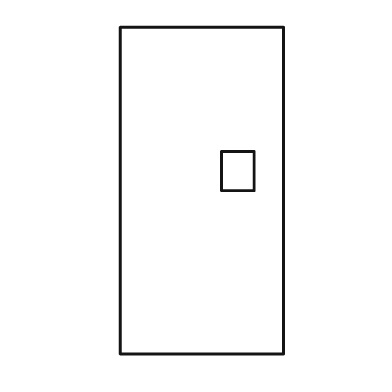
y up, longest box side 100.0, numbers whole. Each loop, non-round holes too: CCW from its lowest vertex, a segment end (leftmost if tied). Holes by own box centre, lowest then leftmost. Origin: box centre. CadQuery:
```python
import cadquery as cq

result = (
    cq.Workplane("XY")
    .moveTo(-25.0, -50.0)
    .lineTo(25.0, -50.0)
    .lineTo(25.0, 50.0)
    .lineTo(-25.0, 50.0)
    .close()
    .moveTo(6.0, 0.0)
    .lineTo(16.0, 0.0)
    .lineTo(16.0, 12.0)
    .lineTo(6.0, 12.0)
    .close()
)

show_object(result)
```